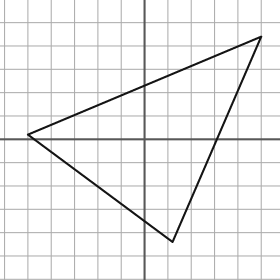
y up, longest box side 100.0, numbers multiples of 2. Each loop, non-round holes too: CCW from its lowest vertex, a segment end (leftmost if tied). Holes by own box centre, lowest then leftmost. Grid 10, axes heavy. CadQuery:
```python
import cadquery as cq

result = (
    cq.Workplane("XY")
    .moveTo(12.0, -44.0)
    .lineTo(50.0, 44.0)
    .lineTo(-50.0, 2.0)
    .close()
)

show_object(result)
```